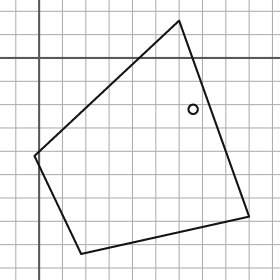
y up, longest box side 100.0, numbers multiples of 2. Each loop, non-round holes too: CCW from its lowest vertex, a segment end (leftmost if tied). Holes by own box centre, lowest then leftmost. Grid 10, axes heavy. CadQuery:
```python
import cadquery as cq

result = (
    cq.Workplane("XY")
    .moveTo(18.0, -84.0)
    .lineTo(90.0, -68.0)
    .lineTo(60.0, 16.0)
    .lineTo(-2.0, -42.0)
    .close()
    .moveTo(66.0, -22.0)
    .circle(2.0)
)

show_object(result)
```